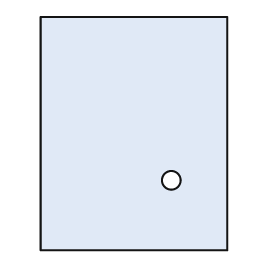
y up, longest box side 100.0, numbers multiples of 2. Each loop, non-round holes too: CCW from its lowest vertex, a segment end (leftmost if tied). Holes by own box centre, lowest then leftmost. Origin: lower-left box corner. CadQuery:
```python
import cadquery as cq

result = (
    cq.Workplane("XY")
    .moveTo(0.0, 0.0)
    .lineTo(80.0, 0.0)
    .lineTo(80.0, 100.0)
    .lineTo(0.0, 100.0)
    .close()
    .moveTo(56.0, 30.0)
    .circle(4.0)
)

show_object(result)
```